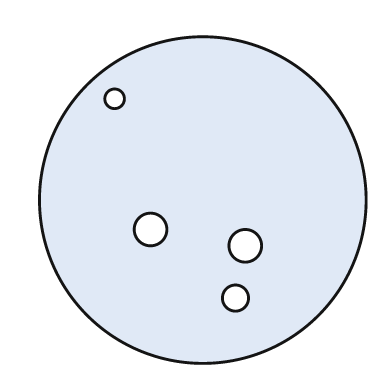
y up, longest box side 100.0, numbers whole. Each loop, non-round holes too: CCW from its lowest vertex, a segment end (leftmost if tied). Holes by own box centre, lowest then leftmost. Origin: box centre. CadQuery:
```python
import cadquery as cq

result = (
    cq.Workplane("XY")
    .moveTo(0.0, 0.0)
    .circle(50.0)
    .moveTo(10.0, -30.0)
    .circle(4.0)
    .moveTo(13.0, -14.0)
    .circle(5.0)
    .moveTo(-16.0, -9.0)
    .circle(5.0)
    .moveTo(-27.0, 31.0)
    .circle(3.0)
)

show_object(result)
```